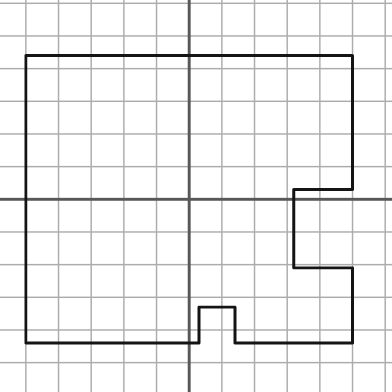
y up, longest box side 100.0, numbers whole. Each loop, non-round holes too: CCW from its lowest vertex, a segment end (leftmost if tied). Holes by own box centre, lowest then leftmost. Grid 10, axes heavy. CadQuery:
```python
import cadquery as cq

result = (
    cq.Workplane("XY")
    .moveTo(-50.0, -44.0)
    .lineTo(3.0, -44.0)
    .lineTo(3.0, -33.0)
    .lineTo(14.0, -33.0)
    .lineTo(14.0, -44.0)
    .lineTo(50.0, -44.0)
    .lineTo(50.0, -21.0)
    .lineTo(32.0, -21.0)
    .lineTo(32.0, 3.0)
    .lineTo(50.0, 3.0)
    .lineTo(50.0, 44.0)
    .lineTo(-50.0, 44.0)
    .close()
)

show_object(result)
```